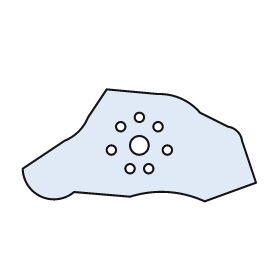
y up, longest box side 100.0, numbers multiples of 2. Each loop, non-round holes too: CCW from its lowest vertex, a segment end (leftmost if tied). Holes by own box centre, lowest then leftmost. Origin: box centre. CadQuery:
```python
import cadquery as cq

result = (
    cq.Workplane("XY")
    .moveTo(28.0, -24.0)
    .lineTo(50.0, -16.0)
    .lineTo(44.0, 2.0)
    .threePointArc((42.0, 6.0), (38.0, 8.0))
    .lineTo(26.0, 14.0)
    .threePointArc((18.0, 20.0), (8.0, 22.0))
    .lineTo(-14.0, 24.0)
    .lineTo(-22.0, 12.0)
    .threePointArc((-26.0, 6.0), (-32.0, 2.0))
    .lineTo(-50.0, -10.0)
    .threePointArc((-42.0, -22.0), (-28.0, -20.0))
    .lineTo(-4.0, -22.0)
    .threePointArc((12.0, -20.0), (28.0, -24.0))
    .close()
    .moveTo(-4.0, -10.0)
    .circle(2.0)
    .moveTo(4.0, -10.0)
    .circle(2.0)
    .moveTo(-12.0, -2.0)
    .circle(2.0)
    .moveTo(12.0, -2.0)
    .circle(2.0)
    .moveTo(0.0, 0.0)
    .circle(4.0)
    .moveTo(-8.0, 8.0)
    .circle(2.0)
    .moveTo(8.0, 8.0)
    .circle(2.0)
    .moveTo(0.0, 12.0)
    .circle(2.0)
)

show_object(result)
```